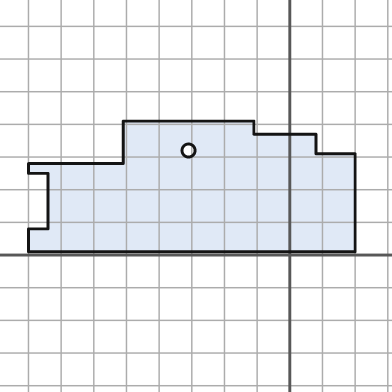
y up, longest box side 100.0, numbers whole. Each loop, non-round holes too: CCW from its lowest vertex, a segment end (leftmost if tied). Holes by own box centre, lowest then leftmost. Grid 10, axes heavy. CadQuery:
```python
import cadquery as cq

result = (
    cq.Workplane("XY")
    .moveTo(-80.0, 1.0)
    .lineTo(20.0, 1.0)
    .lineTo(20.0, 31.0)
    .lineTo(8.0, 31.0)
    .lineTo(8.0, 37.0)
    .lineTo(-11.0, 37.0)
    .lineTo(-11.0, 41.0)
    .lineTo(-51.0, 41.0)
    .lineTo(-51.0, 28.0)
    .lineTo(-80.0, 28.0)
    .lineTo(-80.0, 25.0)
    .lineTo(-74.0, 25.0)
    .lineTo(-74.0, 8.0)
    .lineTo(-80.0, 8.0)
    .close()
    .moveTo(-31.0, 32.0)
    .circle(2.0)
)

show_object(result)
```